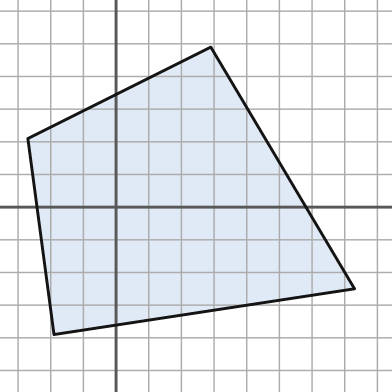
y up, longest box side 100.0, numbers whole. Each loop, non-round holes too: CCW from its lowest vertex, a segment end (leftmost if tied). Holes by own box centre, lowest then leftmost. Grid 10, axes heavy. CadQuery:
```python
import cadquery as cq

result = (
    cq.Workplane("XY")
    .moveTo(-19.0, -39.0)
    .lineTo(73.0, -25.0)
    .lineTo(29.0, 49.0)
    .lineTo(-27.0, 21.0)
    .close()
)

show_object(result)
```